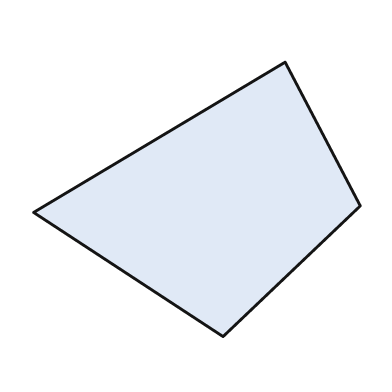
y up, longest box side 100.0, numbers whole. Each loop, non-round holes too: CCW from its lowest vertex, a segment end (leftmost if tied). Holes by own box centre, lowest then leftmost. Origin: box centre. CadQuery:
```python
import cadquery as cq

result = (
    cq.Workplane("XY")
    .moveTo(8.0, -42.0)
    .lineTo(50.0, -2.0)
    .lineTo(27.0, 42.0)
    .lineTo(-50.0, -4.0)
    .close()
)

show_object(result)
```